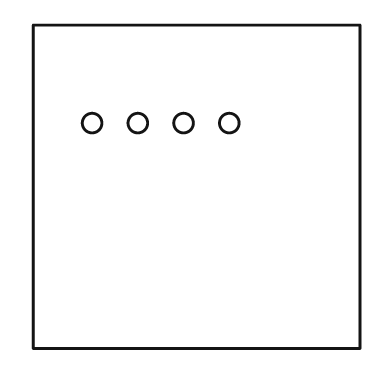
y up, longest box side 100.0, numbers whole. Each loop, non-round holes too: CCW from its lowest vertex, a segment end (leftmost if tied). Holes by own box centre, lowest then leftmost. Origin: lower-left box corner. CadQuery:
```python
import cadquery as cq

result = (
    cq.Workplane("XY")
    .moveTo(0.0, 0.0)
    .lineTo(100.0, 0.0)
    .lineTo(100.0, 99.0)
    .lineTo(0.0, 99.0)
    .close()
    .moveTo(18.0, 69.0)
    .circle(3.0)
    .moveTo(32.0, 69.0)
    .circle(3.0)
    .moveTo(46.0, 69.0)
    .circle(3.0)
    .moveTo(60.0, 69.0)
    .circle(3.0)
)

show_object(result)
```